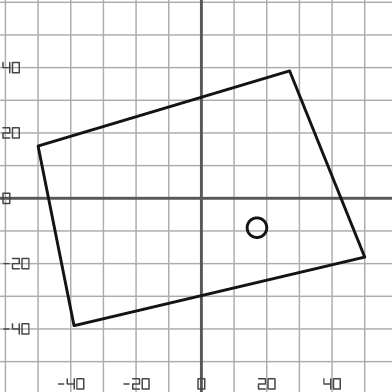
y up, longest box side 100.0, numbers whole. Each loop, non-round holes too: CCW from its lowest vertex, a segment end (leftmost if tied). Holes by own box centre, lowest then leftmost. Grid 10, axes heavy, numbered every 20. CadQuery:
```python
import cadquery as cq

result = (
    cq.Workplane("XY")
    .moveTo(-39.0, -39.0)
    .lineTo(50.0, -18.0)
    .lineTo(27.0, 39.0)
    .lineTo(-50.0, 16.0)
    .close()
    .moveTo(17.0, -9.0)
    .circle(3.0)
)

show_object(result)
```